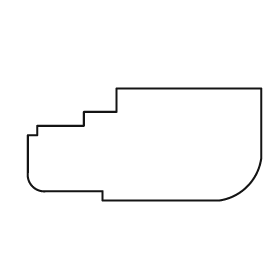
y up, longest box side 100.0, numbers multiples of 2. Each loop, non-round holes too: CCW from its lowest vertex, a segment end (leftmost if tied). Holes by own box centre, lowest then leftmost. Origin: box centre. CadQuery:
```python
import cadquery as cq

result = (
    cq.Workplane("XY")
    .moveTo(-18.0, -24.0)
    .lineTo(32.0, -24.0)
    .threePointArc((44.0, -18.0), (50.0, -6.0))
    .lineTo(50.0, 24.0)
    .lineTo(-12.0, 24.0)
    .lineTo(-12.0, 14.0)
    .lineTo(-26.0, 14.0)
    .lineTo(-26.0, 8.0)
    .lineTo(-46.0, 8.0)
    .lineTo(-46.0, 4.0)
    .lineTo(-50.0, 4.0)
    .lineTo(-50.0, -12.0)
    .threePointArc((-48.0, -18.0), (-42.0, -20.0))
    .lineTo(-18.0, -20.0)
    .close()
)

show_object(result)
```